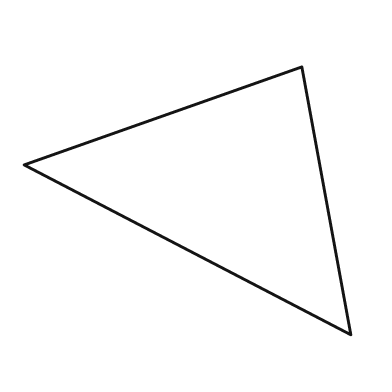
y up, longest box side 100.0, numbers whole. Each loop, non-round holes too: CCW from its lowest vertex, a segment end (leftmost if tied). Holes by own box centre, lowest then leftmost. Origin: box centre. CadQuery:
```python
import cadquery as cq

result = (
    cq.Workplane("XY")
    .moveTo(50.0, -41.0)
    .lineTo(35.0, 41.0)
    .lineTo(-50.0, 11.0)
    .close()
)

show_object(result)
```